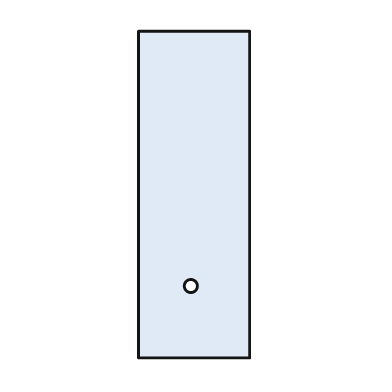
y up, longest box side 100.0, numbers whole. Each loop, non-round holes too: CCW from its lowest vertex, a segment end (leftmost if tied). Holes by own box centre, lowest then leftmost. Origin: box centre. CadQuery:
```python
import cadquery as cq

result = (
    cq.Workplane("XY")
    .moveTo(-17.0, -50.0)
    .lineTo(17.0, -50.0)
    .lineTo(17.0, 50.0)
    .lineTo(-17.0, 50.0)
    .close()
    .moveTo(-1.0, -28.0)
    .circle(2.0)
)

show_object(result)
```